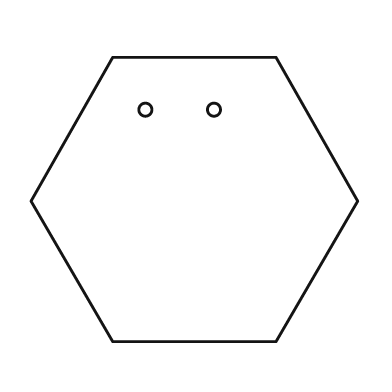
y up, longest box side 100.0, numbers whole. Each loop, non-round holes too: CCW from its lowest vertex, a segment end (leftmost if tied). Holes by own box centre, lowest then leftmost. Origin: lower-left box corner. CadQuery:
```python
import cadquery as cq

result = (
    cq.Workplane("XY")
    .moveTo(25.0, 0.0)
    .lineTo(75.0, 0.0)
    .lineTo(100.0, 43.0)
    .lineTo(75.0, 87.0)
    .lineTo(25.0, 87.0)
    .lineTo(0.0, 43.0)
    .close()
    .moveTo(35.0, 71.0)
    .circle(2.0)
    .moveTo(56.0, 71.0)
    .circle(2.0)
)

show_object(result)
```